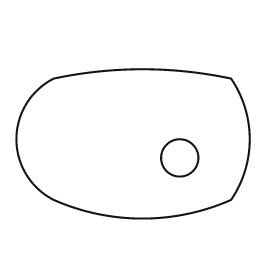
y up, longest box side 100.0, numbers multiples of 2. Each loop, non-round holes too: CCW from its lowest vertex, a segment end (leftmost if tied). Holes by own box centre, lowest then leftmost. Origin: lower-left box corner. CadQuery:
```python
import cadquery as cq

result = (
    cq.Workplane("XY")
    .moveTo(16.0, 8.0)
    .threePointArc((54.0, 0.0), (92.0, 8.0))
    .threePointArc((100.0, 34.0), (92.0, 60.0))
    .threePointArc((54.0, 64.0), (16.0, 60.0))
    .threePointArc((0.0, 34.0), (16.0, 8.0))
    .close()
    .moveTo(70.0, 26.0)
    .circle(8.0)
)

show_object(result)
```